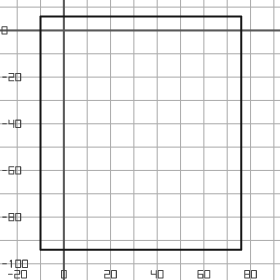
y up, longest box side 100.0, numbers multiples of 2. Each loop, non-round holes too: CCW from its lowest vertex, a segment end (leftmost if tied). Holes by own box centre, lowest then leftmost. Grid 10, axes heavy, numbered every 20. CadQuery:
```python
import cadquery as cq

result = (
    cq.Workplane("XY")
    .moveTo(-10.0, -94.0)
    .lineTo(76.0, -94.0)
    .lineTo(76.0, 6.0)
    .lineTo(-10.0, 6.0)
    .close()
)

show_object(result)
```